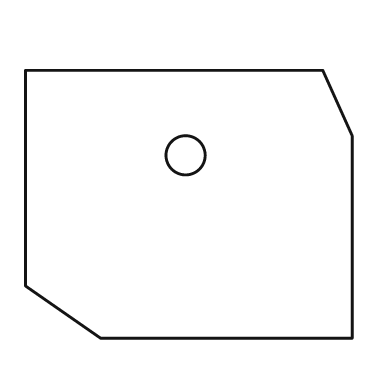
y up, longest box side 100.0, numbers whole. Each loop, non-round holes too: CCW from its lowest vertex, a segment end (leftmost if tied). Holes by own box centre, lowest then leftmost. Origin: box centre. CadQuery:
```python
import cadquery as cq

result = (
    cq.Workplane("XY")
    .moveTo(-27.0, -41.0)
    .lineTo(50.0, -41.0)
    .lineTo(50.0, 21.0)
    .lineTo(41.0, 41.0)
    .lineTo(-50.0, 41.0)
    .lineTo(-50.0, -25.0)
    .close()
    .moveTo(-1.0, 15.0)
    .circle(6.0)
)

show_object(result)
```